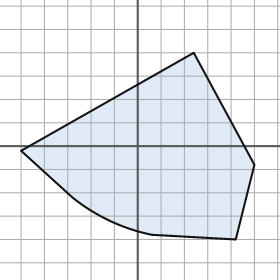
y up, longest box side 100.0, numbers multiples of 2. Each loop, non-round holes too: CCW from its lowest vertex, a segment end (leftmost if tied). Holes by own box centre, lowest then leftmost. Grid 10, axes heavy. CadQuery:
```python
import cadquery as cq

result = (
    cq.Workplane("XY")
    .moveTo(42.0, -40.0)
    .lineTo(50.0, -8.0)
    .lineTo(24.0, 40.0)
    .lineTo(-50.0, -2.0)
    .lineTo(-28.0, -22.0)
    .threePointArc((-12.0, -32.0), (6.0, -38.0))
    .close()
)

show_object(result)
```